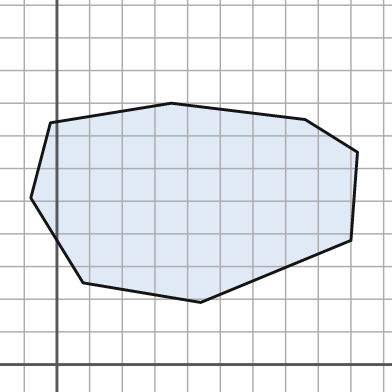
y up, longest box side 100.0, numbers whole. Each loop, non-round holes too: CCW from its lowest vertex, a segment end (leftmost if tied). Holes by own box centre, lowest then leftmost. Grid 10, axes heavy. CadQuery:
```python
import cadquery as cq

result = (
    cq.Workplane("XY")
    .moveTo(44.0, 19.0)
    .lineTo(90.0, 38.0)
    .lineTo(92.0, 65.0)
    .lineTo(76.0, 75.0)
    .lineTo(35.0, 80.0)
    .lineTo(-2.0, 74.0)
    .lineTo(-8.0, 51.0)
    .lineTo(8.0, 25.0)
    .close()
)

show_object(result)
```